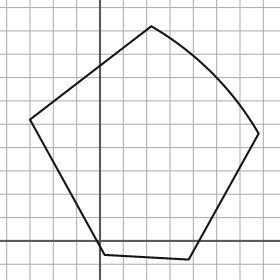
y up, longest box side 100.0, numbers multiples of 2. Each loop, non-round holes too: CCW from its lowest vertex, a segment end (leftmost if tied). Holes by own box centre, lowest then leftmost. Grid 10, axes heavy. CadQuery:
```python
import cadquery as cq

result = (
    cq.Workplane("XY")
    .moveTo(38.0, -8.0)
    .lineTo(68.0, 46.0)
    .threePointArc((48.0, 72.0), (22.0, 92.0))
    .lineTo(-30.0, 52.0)
    .lineTo(2.0, -6.0)
    .close()
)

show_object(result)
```